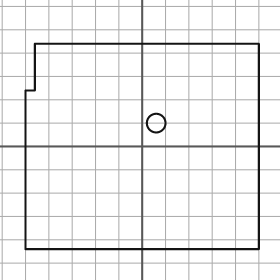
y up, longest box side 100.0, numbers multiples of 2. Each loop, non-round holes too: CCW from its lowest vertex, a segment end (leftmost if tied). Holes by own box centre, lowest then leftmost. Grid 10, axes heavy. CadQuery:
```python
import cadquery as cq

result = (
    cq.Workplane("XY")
    .moveTo(-50.0, -44.0)
    .lineTo(50.0, -44.0)
    .lineTo(50.0, 44.0)
    .lineTo(-46.0, 44.0)
    .lineTo(-46.0, 24.0)
    .lineTo(-50.0, 24.0)
    .close()
    .moveTo(6.0, 10.0)
    .circle(4.0)
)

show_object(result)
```